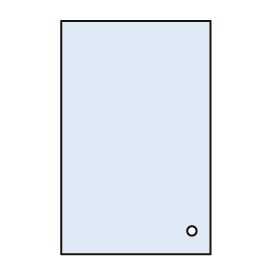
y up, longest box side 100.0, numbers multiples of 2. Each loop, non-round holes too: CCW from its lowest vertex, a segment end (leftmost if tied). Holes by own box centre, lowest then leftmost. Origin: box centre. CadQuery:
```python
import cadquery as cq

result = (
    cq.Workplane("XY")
    .moveTo(-32.0, -50.0)
    .lineTo(32.0, -50.0)
    .lineTo(32.0, 50.0)
    .lineTo(-32.0, 50.0)
    .close()
    .moveTo(24.0, -40.0)
    .circle(2.0)
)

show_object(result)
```